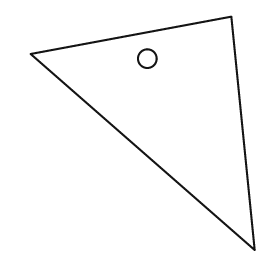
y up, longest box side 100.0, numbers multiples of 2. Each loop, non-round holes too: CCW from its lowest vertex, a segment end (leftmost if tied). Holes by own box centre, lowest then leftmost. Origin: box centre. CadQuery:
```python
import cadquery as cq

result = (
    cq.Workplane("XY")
    .moveTo(48.0, -50.0)
    .lineTo(38.0, 50.0)
    .lineTo(-48.0, 34.0)
    .close()
    .moveTo(2.0, 32.0)
    .circle(4.0)
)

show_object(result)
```